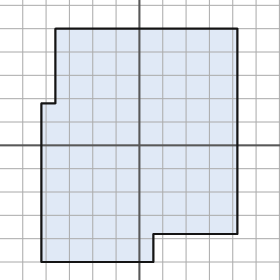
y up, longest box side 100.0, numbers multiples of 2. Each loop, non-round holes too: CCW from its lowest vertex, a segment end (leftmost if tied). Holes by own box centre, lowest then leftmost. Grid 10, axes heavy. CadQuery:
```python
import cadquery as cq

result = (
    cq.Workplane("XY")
    .moveTo(-42.0, -50.0)
    .lineTo(6.0, -50.0)
    .lineTo(6.0, -38.0)
    .lineTo(42.0, -38.0)
    .lineTo(42.0, 50.0)
    .lineTo(-36.0, 50.0)
    .lineTo(-36.0, 18.0)
    .lineTo(-42.0, 18.0)
    .close()
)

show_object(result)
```